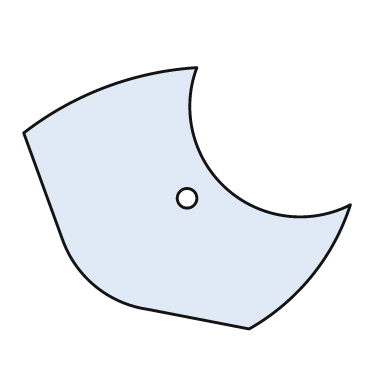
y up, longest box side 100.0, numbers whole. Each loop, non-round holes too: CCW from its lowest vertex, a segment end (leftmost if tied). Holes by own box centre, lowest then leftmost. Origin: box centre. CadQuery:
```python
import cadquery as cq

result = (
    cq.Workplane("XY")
    .moveTo(19.0, -40.0)
    .threePointArc((38.0, -24.0), (50.0, -2.0))
    .threePointArc((12.0, 3.0), (3.0, 40.0))
    .threePointArc((-25.0, 34.0), (-50.0, 20.0))
    .lineTo(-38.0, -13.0)
    .threePointArc((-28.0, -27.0), (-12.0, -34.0))
    .close()
    .moveTo(0.0, 0.0)
    .circle(3.0)
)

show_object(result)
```